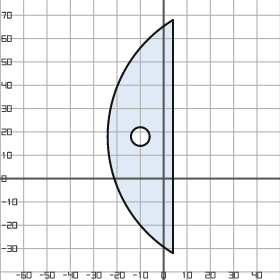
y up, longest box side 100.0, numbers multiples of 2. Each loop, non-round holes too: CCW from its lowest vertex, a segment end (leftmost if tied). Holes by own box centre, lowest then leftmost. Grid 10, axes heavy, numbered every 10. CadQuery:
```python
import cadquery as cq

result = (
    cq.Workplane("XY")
    .moveTo(4.0, -32.0)
    .lineTo(4.0, 68.0)
    .threePointArc((-24.0, 18.0), (4.0, -32.0))
    .close()
    .moveTo(-10.0, 18.0)
    .circle(4.0)
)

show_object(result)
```